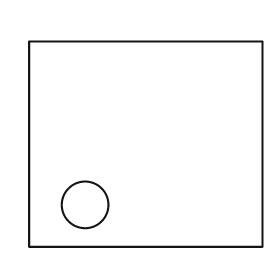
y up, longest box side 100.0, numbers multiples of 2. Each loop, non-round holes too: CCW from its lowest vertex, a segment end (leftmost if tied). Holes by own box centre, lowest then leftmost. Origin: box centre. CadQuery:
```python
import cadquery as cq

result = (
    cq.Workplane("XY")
    .moveTo(-50.0, -44.0)
    .lineTo(50.0, -44.0)
    .lineTo(50.0, 44.0)
    .lineTo(-50.0, 44.0)
    .close()
    .moveTo(-26.0, -26.0)
    .circle(10.0)
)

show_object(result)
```